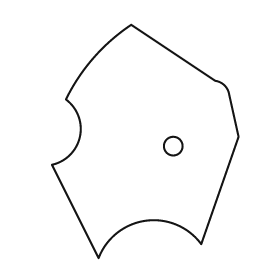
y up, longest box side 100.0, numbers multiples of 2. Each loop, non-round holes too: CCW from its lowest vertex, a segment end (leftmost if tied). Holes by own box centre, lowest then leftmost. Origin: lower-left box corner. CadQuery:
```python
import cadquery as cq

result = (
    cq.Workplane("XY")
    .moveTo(20.0, 0.0)
    .threePointArc((40.0, 16.0), (64.0, 6.0))
    .lineTo(80.0, 52.0)
    .lineTo(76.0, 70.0)
    .threePointArc((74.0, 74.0), (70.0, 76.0))
    .lineTo(34.0, 100.0)
    .threePointArc((18.0, 86.0), (6.0, 68.0))
    .threePointArc((12.0, 52.0), (0.0, 40.0))
    .close()
    .moveTo(52.0, 48.0)
    .circle(4.0)
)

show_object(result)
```